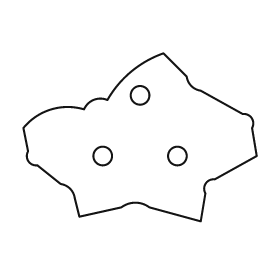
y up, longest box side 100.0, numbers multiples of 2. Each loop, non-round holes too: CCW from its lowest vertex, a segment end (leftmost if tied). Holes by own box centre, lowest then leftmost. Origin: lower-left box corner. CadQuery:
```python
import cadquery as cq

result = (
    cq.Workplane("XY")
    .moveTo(76.0, 0.0)
    .lineTo(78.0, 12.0)
    .threePointArc((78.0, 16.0), (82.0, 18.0))
    .lineTo(100.0, 28.0)
    .lineTo(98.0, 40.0)
    .threePointArc((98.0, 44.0), (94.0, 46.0))
    .lineTo(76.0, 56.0)
    .threePointArc((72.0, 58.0), (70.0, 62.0))
    .lineTo(60.0, 72.0)
    .threePointArc((46.0, 64.0), (36.0, 52.0))
    .threePointArc((30.0, 52.0), (26.0, 48.0))
    .threePointArc((12.0, 48.0), (0.0, 40.0))
    .lineTo(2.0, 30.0)
    .threePointArc((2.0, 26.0), (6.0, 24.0))
    .lineTo(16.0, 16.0)
    .threePointArc((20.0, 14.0), (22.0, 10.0))
    .lineTo(24.0, 2.0)
    .lineTo(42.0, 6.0)
    .threePointArc((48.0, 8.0), (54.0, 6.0))
    .close()
    .moveTo(34.0, 28.0)
    .circle(4.0)
    .moveTo(66.0, 28.0)
    .circle(4.0)
    .moveTo(50.0, 54.0)
    .circle(4.0)
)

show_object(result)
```